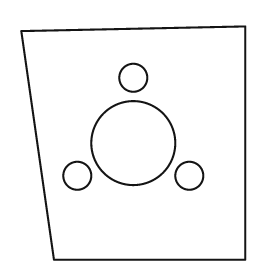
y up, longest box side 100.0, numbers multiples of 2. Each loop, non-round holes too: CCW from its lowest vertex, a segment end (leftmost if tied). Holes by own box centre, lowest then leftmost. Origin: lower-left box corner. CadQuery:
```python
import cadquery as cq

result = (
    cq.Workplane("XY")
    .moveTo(14.0, 0.0)
    .lineTo(96.0, 0.0)
    .lineTo(96.0, 100.0)
    .lineTo(0.0, 98.0)
    .close()
    .moveTo(24.0, 36.0)
    .circle(6.0)
    .moveTo(72.0, 36.0)
    .circle(6.0)
    .moveTo(48.0, 50.0)
    .circle(18.0)
    .moveTo(48.0, 78.0)
    .circle(6.0)
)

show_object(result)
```